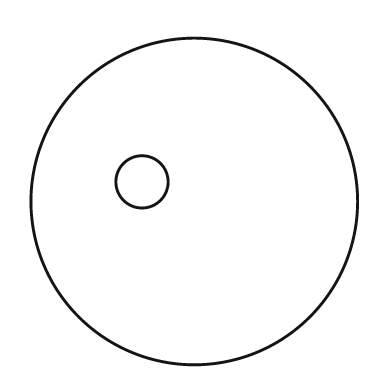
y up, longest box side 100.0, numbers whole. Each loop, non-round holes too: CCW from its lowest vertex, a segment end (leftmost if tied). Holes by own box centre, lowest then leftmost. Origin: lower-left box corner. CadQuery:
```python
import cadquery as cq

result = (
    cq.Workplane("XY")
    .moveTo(50.0, 50.0)
    .circle(50.0)
    .moveTo(34.0, 56.0)
    .circle(8.0)
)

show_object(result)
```